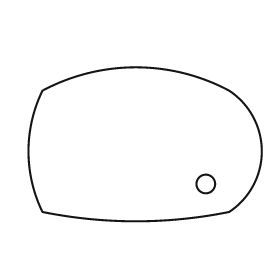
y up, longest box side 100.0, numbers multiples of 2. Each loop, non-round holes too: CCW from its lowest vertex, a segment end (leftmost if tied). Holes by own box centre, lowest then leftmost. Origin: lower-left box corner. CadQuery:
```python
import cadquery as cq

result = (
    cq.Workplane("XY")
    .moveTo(6.0, 4.0)
    .threePointArc((46.0, 0.0), (86.0, 4.0))
    .threePointArc((100.0, 30.0), (86.0, 56.0))
    .threePointArc((46.0, 66.0), (6.0, 56.0))
    .threePointArc((0.0, 30.0), (6.0, 4.0))
    .close()
    .moveTo(76.0, 16.0)
    .circle(4.0)
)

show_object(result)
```